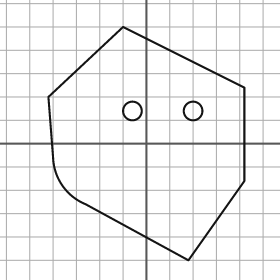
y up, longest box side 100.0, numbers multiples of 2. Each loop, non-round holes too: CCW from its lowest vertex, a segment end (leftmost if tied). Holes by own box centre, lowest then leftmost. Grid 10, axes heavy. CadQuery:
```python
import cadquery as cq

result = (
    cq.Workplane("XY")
    .moveTo(18.0, -50.0)
    .lineTo(42.0, -16.0)
    .lineTo(42.0, 24.0)
    .lineTo(-10.0, 50.0)
    .lineTo(-42.0, 20.0)
    .lineTo(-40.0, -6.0)
    .threePointArc((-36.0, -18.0), (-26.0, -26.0))
    .close()
    .moveTo(-6.0, 14.0)
    .circle(4.0)
    .moveTo(20.0, 14.0)
    .circle(4.0)
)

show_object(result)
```